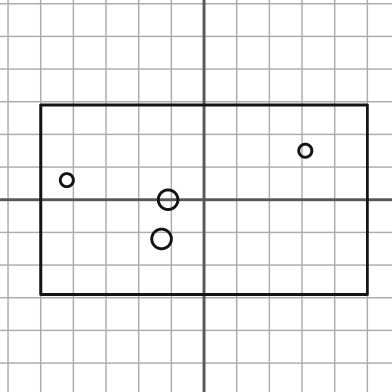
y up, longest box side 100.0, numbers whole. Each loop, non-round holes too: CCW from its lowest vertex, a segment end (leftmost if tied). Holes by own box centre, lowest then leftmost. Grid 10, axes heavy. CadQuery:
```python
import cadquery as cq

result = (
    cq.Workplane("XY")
    .moveTo(-50.0, -29.0)
    .lineTo(50.0, -29.0)
    .lineTo(50.0, 29.0)
    .lineTo(-50.0, 29.0)
    .close()
    .moveTo(-13.0, -12.0)
    .circle(3.0)
    .moveTo(-11.0, 0.0)
    .circle(3.0)
    .moveTo(-42.0, 6.0)
    .circle(2.0)
    .moveTo(31.0, 15.0)
    .circle(2.0)
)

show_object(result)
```